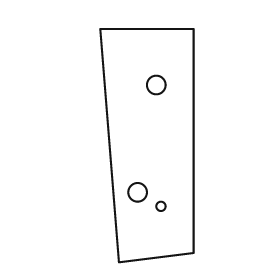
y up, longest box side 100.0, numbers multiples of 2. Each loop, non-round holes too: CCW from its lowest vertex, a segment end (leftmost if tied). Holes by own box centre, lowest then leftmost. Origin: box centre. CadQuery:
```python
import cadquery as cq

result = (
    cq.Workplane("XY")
    .moveTo(-12.0, -50.0)
    .lineTo(20.0, -46.0)
    .lineTo(20.0, 50.0)
    .lineTo(-20.0, 50.0)
    .close()
    .moveTo(6.0, -26.0)
    .circle(2.0)
    .moveTo(-4.0, -20.0)
    .circle(4.0)
    .moveTo(4.0, 26.0)
    .circle(4.0)
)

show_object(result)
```